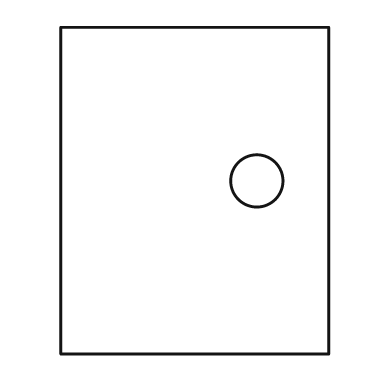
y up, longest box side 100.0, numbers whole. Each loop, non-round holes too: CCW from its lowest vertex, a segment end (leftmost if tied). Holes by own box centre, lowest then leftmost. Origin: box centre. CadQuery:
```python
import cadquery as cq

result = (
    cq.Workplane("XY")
    .moveTo(-41.0, -50.0)
    .lineTo(41.0, -50.0)
    .lineTo(41.0, 50.0)
    .lineTo(-41.0, 50.0)
    .close()
    .moveTo(19.0, 3.0)
    .circle(8.0)
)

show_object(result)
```